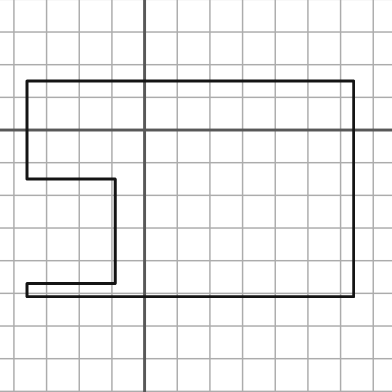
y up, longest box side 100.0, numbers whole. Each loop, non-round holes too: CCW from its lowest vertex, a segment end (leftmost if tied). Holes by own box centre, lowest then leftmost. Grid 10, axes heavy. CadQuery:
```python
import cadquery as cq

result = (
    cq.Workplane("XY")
    .moveTo(-36.0, -51.0)
    .lineTo(64.0, -51.0)
    .lineTo(64.0, 15.0)
    .lineTo(-36.0, 15.0)
    .lineTo(-36.0, -15.0)
    .lineTo(-9.0, -15.0)
    .lineTo(-9.0, -47.0)
    .lineTo(-36.0, -47.0)
    .close()
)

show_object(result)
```